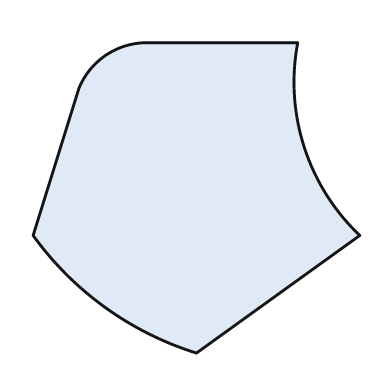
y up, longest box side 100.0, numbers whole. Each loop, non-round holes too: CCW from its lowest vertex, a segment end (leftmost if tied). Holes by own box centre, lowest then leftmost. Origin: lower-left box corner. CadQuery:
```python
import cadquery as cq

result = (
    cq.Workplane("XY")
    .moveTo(50.0, 0.0)
    .lineTo(100.0, 36.0)
    .threePointArc((83.0, 63.0), (81.0, 95.0))
    .lineTo(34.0, 95.0)
    .threePointArc((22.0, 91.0), (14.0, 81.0))
    .lineTo(0.0, 36.0)
    .threePointArc((22.0, 14.0), (50.0, 0.0))
    .close()
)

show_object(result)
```